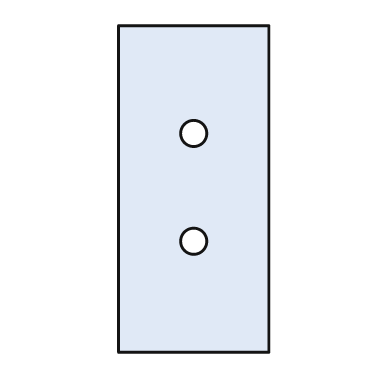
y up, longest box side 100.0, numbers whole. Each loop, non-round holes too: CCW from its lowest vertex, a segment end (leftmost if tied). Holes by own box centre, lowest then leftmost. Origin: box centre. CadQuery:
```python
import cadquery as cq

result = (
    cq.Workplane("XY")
    .moveTo(-23.0, -50.0)
    .lineTo(23.0, -50.0)
    .lineTo(23.0, 50.0)
    .lineTo(-23.0, 50.0)
    .close()
    .moveTo(0.0, -16.0)
    .circle(4.0)
    .moveTo(0.0, 17.0)
    .circle(4.0)
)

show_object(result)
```